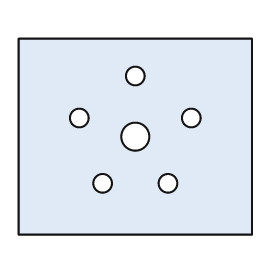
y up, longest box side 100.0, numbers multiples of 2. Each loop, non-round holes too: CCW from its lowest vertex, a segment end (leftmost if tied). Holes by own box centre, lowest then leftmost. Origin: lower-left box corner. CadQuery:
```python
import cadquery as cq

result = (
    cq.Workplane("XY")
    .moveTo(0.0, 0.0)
    .lineTo(100.0, 0.0)
    .lineTo(100.0, 84.0)
    .lineTo(0.0, 84.0)
    .close()
    .moveTo(36.0, 22.0)
    .circle(4.0)
    .moveTo(64.0, 22.0)
    .circle(4.0)
    .moveTo(50.0, 42.0)
    .circle(6.0)
    .moveTo(26.0, 50.0)
    .circle(4.0)
    .moveTo(74.0, 50.0)
    .circle(4.0)
    .moveTo(50.0, 68.0)
    .circle(4.0)
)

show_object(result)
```